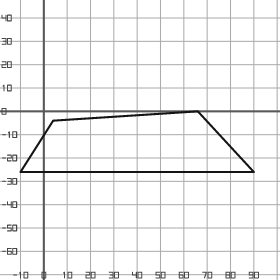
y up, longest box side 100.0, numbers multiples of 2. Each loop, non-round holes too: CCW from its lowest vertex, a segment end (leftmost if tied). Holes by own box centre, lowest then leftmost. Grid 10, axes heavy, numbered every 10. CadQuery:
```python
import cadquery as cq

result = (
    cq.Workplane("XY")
    .moveTo(-10.0, -26.0)
    .lineTo(90.0, -26.0)
    .lineTo(66.0, 0.0)
    .lineTo(4.0, -4.0)
    .close()
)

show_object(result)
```